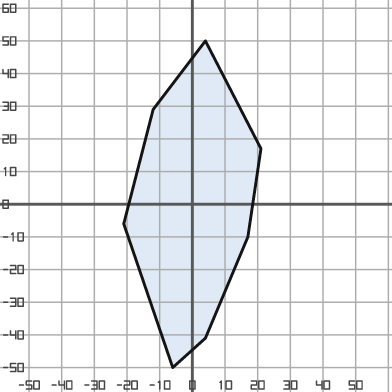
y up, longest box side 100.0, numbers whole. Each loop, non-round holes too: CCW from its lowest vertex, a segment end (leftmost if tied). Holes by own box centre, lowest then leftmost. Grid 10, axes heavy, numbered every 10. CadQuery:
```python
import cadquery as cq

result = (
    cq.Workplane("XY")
    .moveTo(-6.0, -50.0)
    .lineTo(4.0, -41.0)
    .lineTo(17.0, -10.0)
    .lineTo(21.0, 17.0)
    .lineTo(4.0, 50.0)
    .lineTo(-12.0, 29.0)
    .lineTo(-21.0, -6.0)
    .close()
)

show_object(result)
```